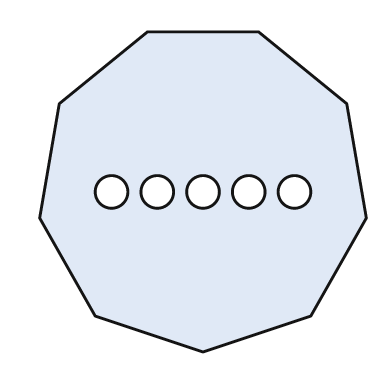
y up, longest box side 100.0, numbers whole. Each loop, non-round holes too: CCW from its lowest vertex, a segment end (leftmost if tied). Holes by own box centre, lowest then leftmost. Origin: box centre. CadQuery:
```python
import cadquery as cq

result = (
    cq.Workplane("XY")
    .moveTo(0.0, -49.0)
    .lineTo(33.0, -38.0)
    .lineTo(50.0, -8.0)
    .lineTo(44.0, 27.0)
    .lineTo(17.0, 49.0)
    .lineTo(-17.0, 49.0)
    .lineTo(-44.0, 27.0)
    .lineTo(-50.0, -8.0)
    .lineTo(-33.0, -38.0)
    .close()
    .moveTo(-28.0, 0.0)
    .circle(5.0)
    .moveTo(-14.0, 0.0)
    .circle(5.0)
    .moveTo(0.0, 0.0)
    .circle(5.0)
    .moveTo(14.0, 0.0)
    .circle(5.0)
    .moveTo(28.0, 0.0)
    .circle(5.0)
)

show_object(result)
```